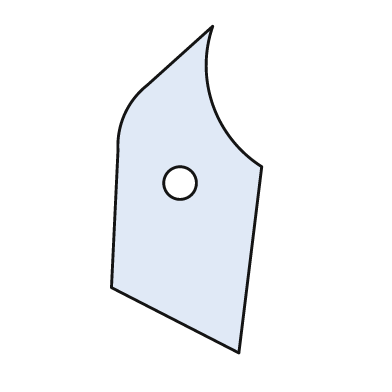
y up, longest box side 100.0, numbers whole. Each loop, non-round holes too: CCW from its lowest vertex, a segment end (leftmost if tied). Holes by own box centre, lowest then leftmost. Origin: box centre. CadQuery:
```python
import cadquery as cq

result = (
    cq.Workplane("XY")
    .moveTo(16.0, -50.0)
    .lineTo(23.0, 7.0)
    .threePointArc((8.0, 26.0), (8.0, 50.0))
    .lineTo(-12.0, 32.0)
    .threePointArc((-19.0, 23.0), (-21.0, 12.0))
    .lineTo(-23.0, -30.0)
    .close()
    .moveTo(-2.0, 2.0)
    .circle(5.0)
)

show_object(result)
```